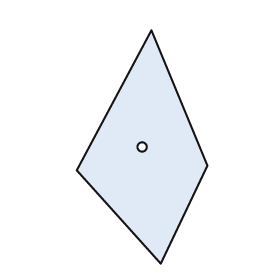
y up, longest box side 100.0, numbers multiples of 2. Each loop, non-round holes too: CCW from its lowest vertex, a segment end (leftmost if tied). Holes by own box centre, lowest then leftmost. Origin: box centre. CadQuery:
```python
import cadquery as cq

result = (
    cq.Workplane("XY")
    .moveTo(8.0, -50.0)
    .lineTo(28.0, -8.0)
    .lineTo(4.0, 50.0)
    .lineTo(-28.0, -10.0)
    .close()
    .moveTo(0.0, 0.0)
    .circle(2.0)
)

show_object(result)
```